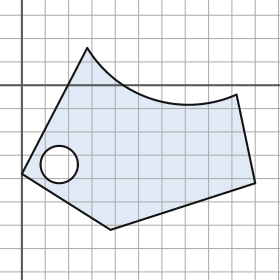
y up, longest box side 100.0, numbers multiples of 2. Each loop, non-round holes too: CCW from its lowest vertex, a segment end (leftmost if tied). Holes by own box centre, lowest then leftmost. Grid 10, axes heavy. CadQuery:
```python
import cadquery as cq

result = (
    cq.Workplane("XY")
    .moveTo(38.0, -62.0)
    .lineTo(100.0, -42.0)
    .lineTo(92.0, -4.0)
    .threePointArc((56.0, -6.0), (28.0, 16.0))
    .lineTo(0.0, -38.0)
    .close()
    .moveTo(16.0, -34.0)
    .circle(8.0)
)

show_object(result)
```